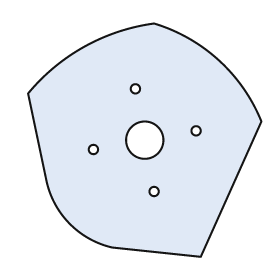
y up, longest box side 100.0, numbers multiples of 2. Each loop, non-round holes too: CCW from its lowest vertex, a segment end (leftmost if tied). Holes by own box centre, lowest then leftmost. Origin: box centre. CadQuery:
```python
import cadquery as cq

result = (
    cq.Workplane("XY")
    .moveTo(24.0, -50.0)
    .lineTo(50.0, 8.0)
    .threePointArc((32.0, 34.0), (4.0, 50.0))
    .threePointArc((-26.0, 40.0), (-50.0, 20.0))
    .lineTo(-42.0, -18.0)
    .threePointArc((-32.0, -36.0), (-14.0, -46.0))
    .close()
    .moveTo(4.0, -22.0)
    .circle(2.0)
    .moveTo(-22.0, -4.0)
    .circle(2.0)
    .moveTo(0.0, 0.0)
    .circle(8.0)
    .moveTo(22.0, 4.0)
    .circle(2.0)
    .moveTo(-4.0, 22.0)
    .circle(2.0)
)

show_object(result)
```